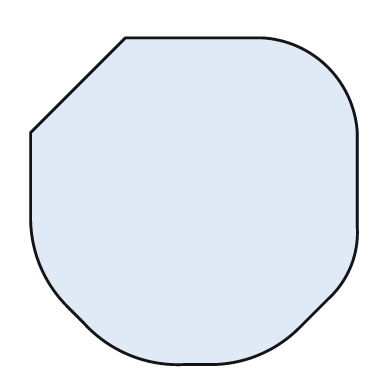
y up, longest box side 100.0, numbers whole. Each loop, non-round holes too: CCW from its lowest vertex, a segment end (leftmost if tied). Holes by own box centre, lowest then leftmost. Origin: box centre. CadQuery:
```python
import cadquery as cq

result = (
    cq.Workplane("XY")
    .moveTo(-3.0, -50.0)
    .lineTo(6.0, -50.0)
    .threePointArc((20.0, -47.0), (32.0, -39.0))
    .lineTo(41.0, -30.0)
    .threePointArc((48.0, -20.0), (50.0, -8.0))
    .lineTo(50.0, 21.0)
    .threePointArc((41.0, 41.0), (21.0, 50.0))
    .lineTo(-21.0, 50.0)
    .lineTo(-50.0, 21.0)
    .lineTo(-50.0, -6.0)
    .threePointArc((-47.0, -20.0), (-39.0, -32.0))
    .lineTo(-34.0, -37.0)
    .threePointArc((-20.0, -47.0), (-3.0, -50.0))
    .close()
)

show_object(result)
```